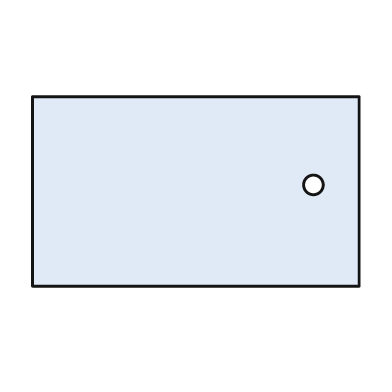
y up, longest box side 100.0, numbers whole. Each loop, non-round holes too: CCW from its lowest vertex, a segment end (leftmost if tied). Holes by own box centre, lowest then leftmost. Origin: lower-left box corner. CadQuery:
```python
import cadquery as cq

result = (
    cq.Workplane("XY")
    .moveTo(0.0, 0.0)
    .lineTo(100.0, 0.0)
    .lineTo(100.0, 58.0)
    .lineTo(0.0, 58.0)
    .close()
    .moveTo(86.0, 31.0)
    .circle(3.0)
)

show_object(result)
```